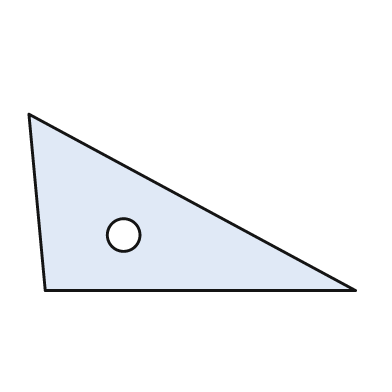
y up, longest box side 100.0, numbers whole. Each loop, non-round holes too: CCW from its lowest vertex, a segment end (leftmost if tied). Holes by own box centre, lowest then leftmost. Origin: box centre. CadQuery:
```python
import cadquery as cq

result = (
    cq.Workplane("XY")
    .moveTo(-45.0, -27.0)
    .lineTo(50.0, -27.0)
    .lineTo(-50.0, 27.0)
    .close()
    .moveTo(-21.0, -10.0)
    .circle(5.0)
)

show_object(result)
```